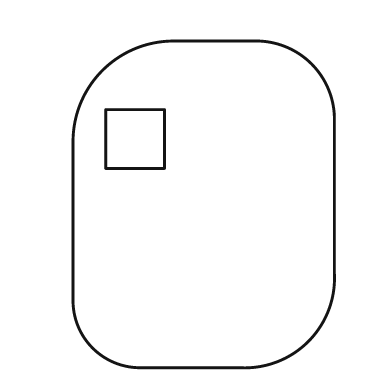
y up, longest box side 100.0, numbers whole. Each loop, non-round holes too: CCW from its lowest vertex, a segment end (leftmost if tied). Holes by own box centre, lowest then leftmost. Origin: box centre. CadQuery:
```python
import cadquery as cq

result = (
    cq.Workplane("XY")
    .moveTo(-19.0, -50.0)
    .lineTo(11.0, -50.0)
    .threePointArc((32.0, -42.0), (40.0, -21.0))
    .lineTo(40.0, 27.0)
    .threePointArc((33.0, 43.0), (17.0, 50.0))
    .lineTo(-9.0, 50.0)
    .threePointArc((-31.0, 41.0), (-40.0, 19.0))
    .lineTo(-40.0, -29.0)
    .threePointArc((-34.0, -44.0), (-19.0, -50.0))
    .close()
    .moveTo(-30.0, 11.0)
    .lineTo(-12.0, 11.0)
    .lineTo(-12.0, 29.0)
    .lineTo(-30.0, 29.0)
    .close()
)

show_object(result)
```